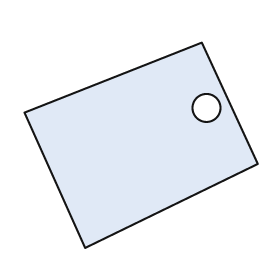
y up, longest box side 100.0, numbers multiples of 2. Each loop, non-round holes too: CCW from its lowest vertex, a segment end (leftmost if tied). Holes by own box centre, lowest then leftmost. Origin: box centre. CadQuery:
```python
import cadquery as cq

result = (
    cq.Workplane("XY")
    .moveTo(-24.0, -44.0)
    .lineTo(50.0, -8.0)
    .lineTo(26.0, 44.0)
    .lineTo(-50.0, 14.0)
    .close()
    .moveTo(28.0, 16.0)
    .circle(6.0)
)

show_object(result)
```